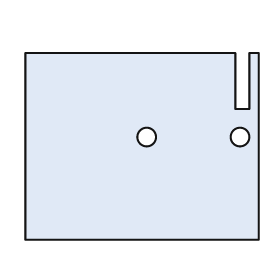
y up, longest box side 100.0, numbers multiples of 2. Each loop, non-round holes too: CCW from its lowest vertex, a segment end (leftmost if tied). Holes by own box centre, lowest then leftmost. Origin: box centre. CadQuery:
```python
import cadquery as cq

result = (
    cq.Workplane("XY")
    .moveTo(-50.0, -40.0)
    .lineTo(50.0, -40.0)
    .lineTo(50.0, 40.0)
    .lineTo(46.0, 40.0)
    .lineTo(46.0, 16.0)
    .lineTo(40.0, 16.0)
    .lineTo(40.0, 40.0)
    .lineTo(-50.0, 40.0)
    .close()
    .moveTo(2.0, 4.0)
    .circle(4.0)
    .moveTo(42.0, 4.0)
    .circle(4.0)
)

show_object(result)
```